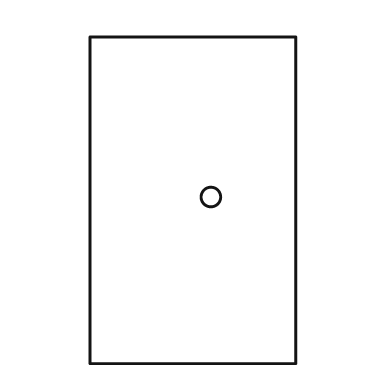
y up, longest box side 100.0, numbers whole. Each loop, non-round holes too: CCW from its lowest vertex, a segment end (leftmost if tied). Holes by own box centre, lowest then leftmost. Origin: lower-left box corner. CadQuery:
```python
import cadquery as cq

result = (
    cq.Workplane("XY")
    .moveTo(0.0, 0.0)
    .lineTo(63.0, 0.0)
    .lineTo(63.0, 100.0)
    .lineTo(0.0, 100.0)
    .close()
    .moveTo(37.0, 51.0)
    .circle(3.0)
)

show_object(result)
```